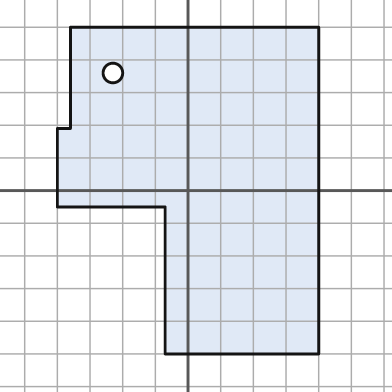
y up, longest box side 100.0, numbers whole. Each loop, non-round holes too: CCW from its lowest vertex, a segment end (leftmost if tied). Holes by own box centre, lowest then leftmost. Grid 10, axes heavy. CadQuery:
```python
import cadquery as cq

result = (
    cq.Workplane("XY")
    .moveTo(-7.0, -50.0)
    .lineTo(40.0, -50.0)
    .lineTo(40.0, 50.0)
    .lineTo(-36.0, 50.0)
    .lineTo(-36.0, 19.0)
    .lineTo(-40.0, 19.0)
    .lineTo(-40.0, -5.0)
    .lineTo(-7.0, -5.0)
    .close()
    .moveTo(-23.0, 36.0)
    .circle(3.0)
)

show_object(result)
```